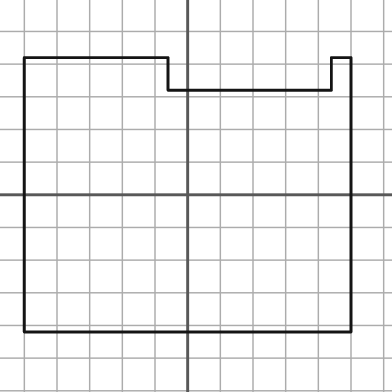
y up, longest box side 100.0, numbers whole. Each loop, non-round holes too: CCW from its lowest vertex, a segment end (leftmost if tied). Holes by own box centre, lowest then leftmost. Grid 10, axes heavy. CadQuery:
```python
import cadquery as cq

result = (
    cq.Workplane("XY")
    .moveTo(-50.0, -42.0)
    .lineTo(50.0, -42.0)
    .lineTo(50.0, 42.0)
    .lineTo(44.0, 42.0)
    .lineTo(44.0, 32.0)
    .lineTo(-6.0, 32.0)
    .lineTo(-6.0, 42.0)
    .lineTo(-50.0, 42.0)
    .close()
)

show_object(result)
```